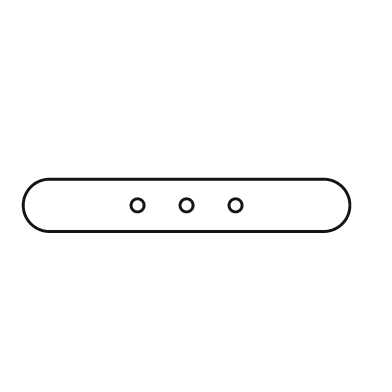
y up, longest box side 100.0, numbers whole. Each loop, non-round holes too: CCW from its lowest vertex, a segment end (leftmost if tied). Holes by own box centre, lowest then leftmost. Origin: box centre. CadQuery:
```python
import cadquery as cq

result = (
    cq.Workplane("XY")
    .moveTo(-42.0, -8.0)
    .lineTo(42.0, -8.0)
    .threePointArc((50.0, 0.0), (42.0, 8.0))
    .lineTo(-42.0, 8.0)
    .threePointArc((-50.0, 0.0), (-42.0, -8.0))
    .close()
    .moveTo(-15.0, 0.0)
    .circle(2.0)
    .moveTo(0.0, 0.0)
    .circle(2.0)
    .moveTo(15.0, 0.0)
    .circle(2.0)
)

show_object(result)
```